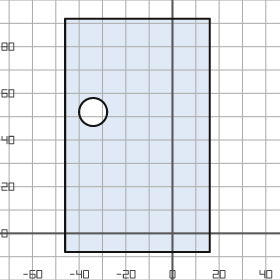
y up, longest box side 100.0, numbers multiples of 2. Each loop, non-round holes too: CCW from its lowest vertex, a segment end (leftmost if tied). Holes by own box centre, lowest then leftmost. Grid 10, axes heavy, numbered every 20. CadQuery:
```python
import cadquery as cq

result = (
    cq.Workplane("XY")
    .moveTo(-46.0, -8.0)
    .lineTo(16.0, -8.0)
    .lineTo(16.0, 92.0)
    .lineTo(-46.0, 92.0)
    .close()
    .moveTo(-34.0, 52.0)
    .circle(6.0)
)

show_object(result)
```